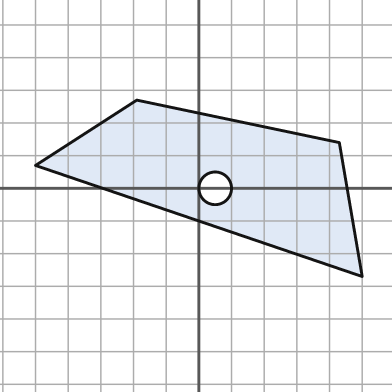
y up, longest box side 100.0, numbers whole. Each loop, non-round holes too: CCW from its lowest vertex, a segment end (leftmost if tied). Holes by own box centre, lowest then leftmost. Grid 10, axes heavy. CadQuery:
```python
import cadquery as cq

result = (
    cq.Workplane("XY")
    .moveTo(50.0, -27.0)
    .lineTo(43.0, 14.0)
    .lineTo(-19.0, 27.0)
    .lineTo(-50.0, 7.0)
    .close()
    .moveTo(5.0, 0.0)
    .circle(5.0)
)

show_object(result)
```